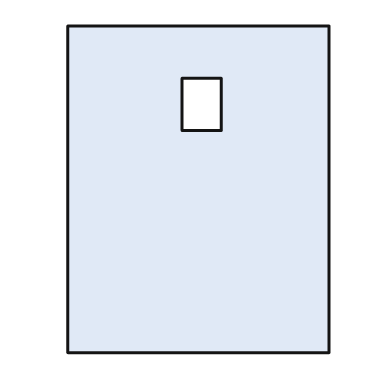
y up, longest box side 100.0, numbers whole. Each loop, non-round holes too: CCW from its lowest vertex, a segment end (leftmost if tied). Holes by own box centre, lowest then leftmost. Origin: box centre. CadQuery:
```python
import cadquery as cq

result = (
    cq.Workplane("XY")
    .moveTo(-40.0, -50.0)
    .lineTo(40.0, -50.0)
    .lineTo(40.0, 50.0)
    .lineTo(-40.0, 50.0)
    .close()
    .moveTo(-5.0, 18.0)
    .lineTo(7.0, 18.0)
    .lineTo(7.0, 34.0)
    .lineTo(-5.0, 34.0)
    .close()
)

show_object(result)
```